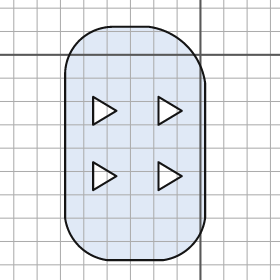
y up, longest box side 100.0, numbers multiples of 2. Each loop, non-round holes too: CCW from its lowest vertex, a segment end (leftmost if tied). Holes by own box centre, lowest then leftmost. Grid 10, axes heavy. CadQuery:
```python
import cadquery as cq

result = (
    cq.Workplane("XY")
    .moveTo(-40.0, -88.0)
    .lineTo(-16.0, -88.0)
    .threePointArc((-4.0, -82.0), (2.0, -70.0))
    .lineTo(2.0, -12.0)
    .threePointArc((-6.0, 4.0), (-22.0, 12.0))
    .lineTo(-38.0, 12.0)
    .threePointArc((-52.0, 6.0), (-58.0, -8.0))
    .lineTo(-58.0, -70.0)
    .threePointArc((-52.0, -82.0), (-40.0, -88.0))
    .close()
    .moveTo(-46.0, -58.0)
    .lineTo(-36.0, -52.0)
    .lineTo(-46.0, -46.0)
    .close()
    .moveTo(-18.0, -58.0)
    .lineTo(-8.0, -52.0)
    .lineTo(-18.0, -46.0)
    .close()
    .moveTo(-46.0, -30.0)
    .lineTo(-36.0, -24.0)
    .lineTo(-46.0, -18.0)
    .close()
    .moveTo(-18.0, -30.0)
    .lineTo(-8.0, -24.0)
    .lineTo(-18.0, -18.0)
    .close()
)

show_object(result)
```